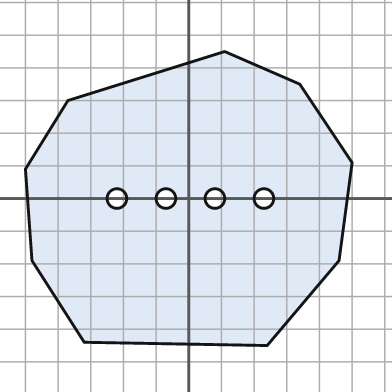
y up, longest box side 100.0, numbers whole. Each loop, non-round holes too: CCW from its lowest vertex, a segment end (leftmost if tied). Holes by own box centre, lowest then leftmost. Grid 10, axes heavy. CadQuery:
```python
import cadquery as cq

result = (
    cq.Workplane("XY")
    .moveTo(24.0, -45.0)
    .lineTo(46.0, -19.0)
    .lineTo(50.0, 11.0)
    .lineTo(34.0, 35.0)
    .lineTo(11.0, 45.0)
    .lineTo(-37.0, 30.0)
    .lineTo(-50.0, 9.0)
    .lineTo(-48.0, -19.0)
    .lineTo(-32.0, -44.0)
    .close()
    .moveTo(-22.0, 0.0)
    .circle(3.0)
    .moveTo(-7.0, 0.0)
    .circle(3.0)
    .moveTo(8.0, 0.0)
    .circle(3.0)
    .moveTo(23.0, 0.0)
    .circle(3.0)
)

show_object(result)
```